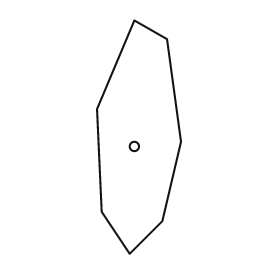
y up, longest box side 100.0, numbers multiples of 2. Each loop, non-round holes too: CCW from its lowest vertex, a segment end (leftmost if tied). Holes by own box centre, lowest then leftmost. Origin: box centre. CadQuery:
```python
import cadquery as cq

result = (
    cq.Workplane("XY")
    .moveTo(-4.0, -50.0)
    .lineTo(10.0, -36.0)
    .lineTo(18.0, -2.0)
    .lineTo(12.0, 42.0)
    .lineTo(-2.0, 50.0)
    .lineTo(-18.0, 12.0)
    .lineTo(-16.0, -32.0)
    .close()
    .moveTo(-2.0, -4.0)
    .circle(2.0)
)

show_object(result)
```